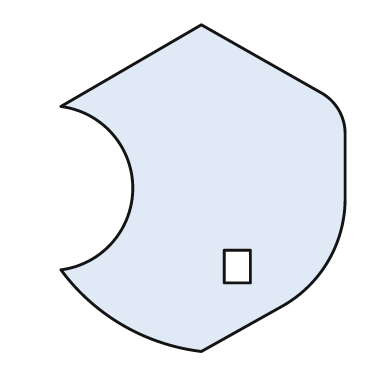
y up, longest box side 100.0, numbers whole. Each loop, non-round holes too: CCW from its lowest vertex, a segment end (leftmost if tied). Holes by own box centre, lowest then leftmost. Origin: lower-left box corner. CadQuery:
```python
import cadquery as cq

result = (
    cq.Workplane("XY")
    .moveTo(43.0, 0.0)
    .lineTo(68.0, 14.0)
    .threePointArc((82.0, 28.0), (87.0, 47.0))
    .lineTo(87.0, 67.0)
    .threePointArc((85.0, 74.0), (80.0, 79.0))
    .lineTo(43.0, 100.0)
    .lineTo(0.0, 75.0)
    .threePointArc((22.0, 50.0), (0.0, 25.0))
    .threePointArc((19.0, 8.0), (43.0, 0.0))
    .close()
    .moveTo(50.0, 21.0)
    .lineTo(58.0, 21.0)
    .lineTo(58.0, 31.0)
    .lineTo(50.0, 31.0)
    .close()
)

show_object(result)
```